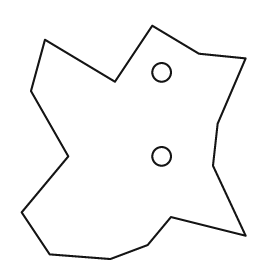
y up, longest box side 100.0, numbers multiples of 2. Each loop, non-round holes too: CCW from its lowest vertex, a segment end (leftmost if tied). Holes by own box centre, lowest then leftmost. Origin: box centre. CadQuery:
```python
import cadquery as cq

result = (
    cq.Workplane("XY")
    .moveTo(-10.0, -50.0)
    .lineTo(6.0, -44.0)
    .lineTo(16.0, -32.0)
    .lineTo(48.0, -40.0)
    .lineTo(34.0, -10.0)
    .lineTo(36.0, 8.0)
    .lineTo(48.0, 36.0)
    .lineTo(28.0, 38.0)
    .lineTo(8.0, 50.0)
    .lineTo(-8.0, 26.0)
    .lineTo(-38.0, 44.0)
    .lineTo(-44.0, 22.0)
    .lineTo(-28.0, -6.0)
    .lineTo(-48.0, -30.0)
    .lineTo(-36.0, -48.0)
    .close()
    .moveTo(12.0, -6.0)
    .circle(4.0)
    .moveTo(12.0, 30.0)
    .circle(4.0)
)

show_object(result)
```